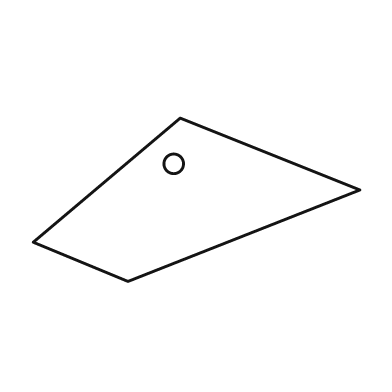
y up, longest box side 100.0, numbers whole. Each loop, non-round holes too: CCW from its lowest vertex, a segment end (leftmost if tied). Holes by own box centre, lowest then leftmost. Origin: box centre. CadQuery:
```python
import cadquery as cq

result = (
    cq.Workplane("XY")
    .moveTo(-21.0, -25.0)
    .lineTo(50.0, 3.0)
    .lineTo(-5.0, 25.0)
    .lineTo(-50.0, -13.0)
    .close()
    .moveTo(-7.0, 11.0)
    .circle(3.0)
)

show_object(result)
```